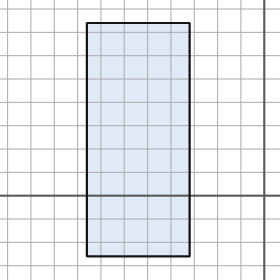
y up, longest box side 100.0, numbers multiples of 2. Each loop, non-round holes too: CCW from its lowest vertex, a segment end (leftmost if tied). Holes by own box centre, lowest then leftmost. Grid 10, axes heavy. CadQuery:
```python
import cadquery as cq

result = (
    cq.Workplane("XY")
    .moveTo(-76.0, -26.0)
    .lineTo(-32.0, -26.0)
    .lineTo(-32.0, 74.0)
    .lineTo(-76.0, 74.0)
    .close()
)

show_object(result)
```